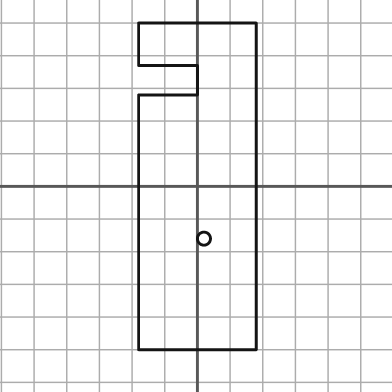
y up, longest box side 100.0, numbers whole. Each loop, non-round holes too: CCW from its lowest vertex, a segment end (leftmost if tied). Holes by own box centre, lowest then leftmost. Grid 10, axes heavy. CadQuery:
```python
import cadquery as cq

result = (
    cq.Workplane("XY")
    .moveTo(-18.0, -50.0)
    .lineTo(18.0, -50.0)
    .lineTo(18.0, 50.0)
    .lineTo(-18.0, 50.0)
    .lineTo(-18.0, 37.0)
    .lineTo(0.0, 37.0)
    .lineTo(0.0, 28.0)
    .lineTo(-18.0, 28.0)
    .close()
    .moveTo(2.0, -16.0)
    .circle(2.0)
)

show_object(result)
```